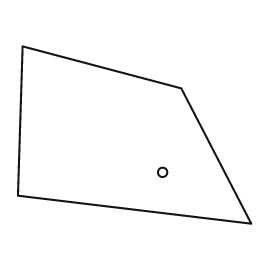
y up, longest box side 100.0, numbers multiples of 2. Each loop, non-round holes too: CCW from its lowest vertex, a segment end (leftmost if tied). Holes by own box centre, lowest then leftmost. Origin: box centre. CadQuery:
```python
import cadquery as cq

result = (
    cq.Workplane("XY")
    .moveTo(50.0, -38.0)
    .lineTo(20.0, 20.0)
    .lineTo(-48.0, 38.0)
    .lineTo(-50.0, -26.0)
    .close()
    .moveTo(12.0, -16.0)
    .circle(2.0)
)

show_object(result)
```